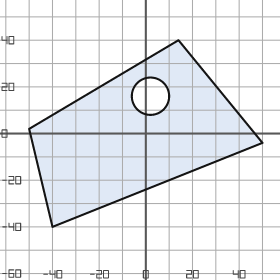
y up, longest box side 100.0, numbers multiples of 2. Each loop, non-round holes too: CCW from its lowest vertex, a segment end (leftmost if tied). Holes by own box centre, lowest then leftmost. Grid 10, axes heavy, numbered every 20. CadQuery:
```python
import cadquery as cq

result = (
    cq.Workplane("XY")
    .moveTo(-40.0, -40.0)
    .lineTo(50.0, -4.0)
    .lineTo(14.0, 40.0)
    .lineTo(-50.0, 2.0)
    .close()
    .moveTo(2.0, 16.0)
    .circle(8.0)
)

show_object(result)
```